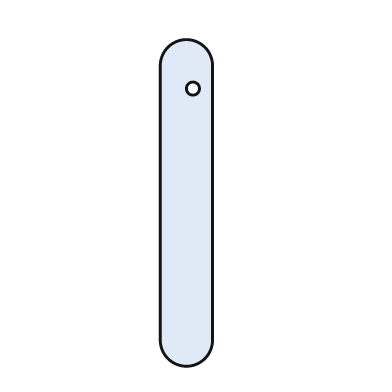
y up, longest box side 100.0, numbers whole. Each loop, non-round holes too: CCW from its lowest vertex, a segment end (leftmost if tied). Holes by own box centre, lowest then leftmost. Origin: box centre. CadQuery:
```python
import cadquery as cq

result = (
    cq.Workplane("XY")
    .moveTo(-8.0, -42.0)
    .threePointArc((0.0, -50.0), (8.0, -42.0))
    .lineTo(8.0, 42.0)
    .threePointArc((0.0, 50.0), (-8.0, 42.0))
    .close()
    .moveTo(2.0, 35.0)
    .circle(2.0)
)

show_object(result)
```